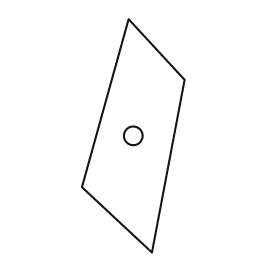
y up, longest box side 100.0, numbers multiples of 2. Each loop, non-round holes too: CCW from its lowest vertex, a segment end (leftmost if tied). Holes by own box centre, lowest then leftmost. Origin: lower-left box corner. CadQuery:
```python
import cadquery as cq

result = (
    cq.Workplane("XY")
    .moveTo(30.0, 0.0)
    .lineTo(44.0, 74.0)
    .lineTo(20.0, 100.0)
    .lineTo(0.0, 28.0)
    .close()
    .moveTo(22.0, 50.0)
    .circle(4.0)
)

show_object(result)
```